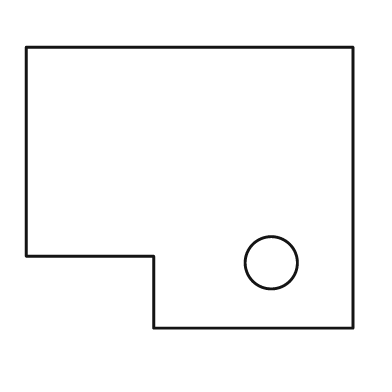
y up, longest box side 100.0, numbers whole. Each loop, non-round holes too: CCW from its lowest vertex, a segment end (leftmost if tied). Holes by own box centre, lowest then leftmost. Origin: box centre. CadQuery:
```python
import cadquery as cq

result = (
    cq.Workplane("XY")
    .moveTo(-11.0, -43.0)
    .lineTo(50.0, -43.0)
    .lineTo(50.0, 43.0)
    .lineTo(-50.0, 43.0)
    .lineTo(-50.0, -21.0)
    .lineTo(-11.0, -21.0)
    .close()
    .moveTo(25.0, -23.0)
    .circle(8.0)
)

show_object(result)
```